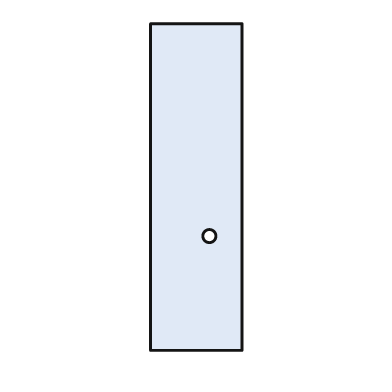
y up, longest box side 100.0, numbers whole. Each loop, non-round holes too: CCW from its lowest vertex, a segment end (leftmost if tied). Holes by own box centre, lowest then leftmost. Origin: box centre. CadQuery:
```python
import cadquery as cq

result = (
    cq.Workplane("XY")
    .moveTo(-14.0, -50.0)
    .lineTo(14.0, -50.0)
    .lineTo(14.0, 50.0)
    .lineTo(-14.0, 50.0)
    .close()
    .moveTo(4.0, -15.0)
    .circle(2.0)
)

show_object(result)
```